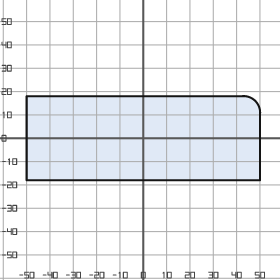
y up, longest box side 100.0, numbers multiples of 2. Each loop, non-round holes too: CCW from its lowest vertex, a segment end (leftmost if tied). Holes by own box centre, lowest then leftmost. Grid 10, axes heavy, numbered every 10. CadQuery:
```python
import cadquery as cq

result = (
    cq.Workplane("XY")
    .moveTo(-50.0, -18.0)
    .lineTo(50.0, -18.0)
    .lineTo(50.0, 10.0)
    .threePointArc((48.0, 16.0), (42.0, 18.0))
    .lineTo(-50.0, 18.0)
    .close()
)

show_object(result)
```